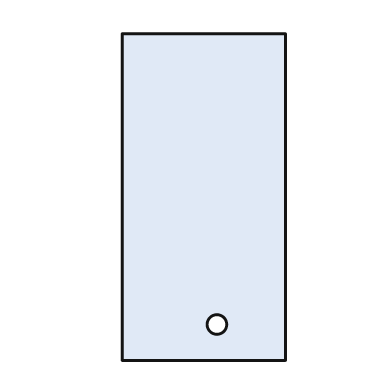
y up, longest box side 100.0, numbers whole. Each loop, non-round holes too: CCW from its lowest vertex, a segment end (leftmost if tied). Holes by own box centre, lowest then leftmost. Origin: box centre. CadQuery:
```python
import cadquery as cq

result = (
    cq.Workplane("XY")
    .moveTo(-25.0, -50.0)
    .lineTo(25.0, -50.0)
    .lineTo(25.0, 50.0)
    .lineTo(-25.0, 50.0)
    .close()
    .moveTo(4.0, -39.0)
    .circle(3.0)
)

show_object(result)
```